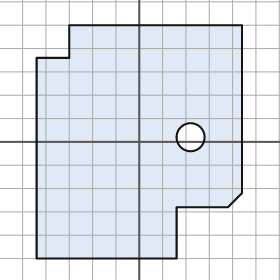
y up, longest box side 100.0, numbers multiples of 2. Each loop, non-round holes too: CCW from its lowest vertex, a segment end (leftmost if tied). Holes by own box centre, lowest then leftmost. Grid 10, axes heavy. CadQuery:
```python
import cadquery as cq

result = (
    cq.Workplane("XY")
    .moveTo(-44.0, -50.0)
    .lineTo(16.0, -50.0)
    .lineTo(16.0, -28.0)
    .lineTo(38.0, -28.0)
    .lineTo(44.0, -22.0)
    .lineTo(44.0, 50.0)
    .lineTo(-30.0, 50.0)
    .lineTo(-30.0, 36.0)
    .lineTo(-44.0, 36.0)
    .close()
    .moveTo(22.0, 2.0)
    .circle(6.0)
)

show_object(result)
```